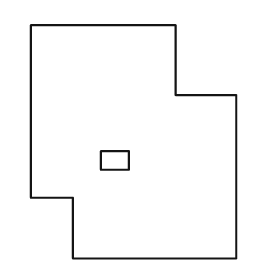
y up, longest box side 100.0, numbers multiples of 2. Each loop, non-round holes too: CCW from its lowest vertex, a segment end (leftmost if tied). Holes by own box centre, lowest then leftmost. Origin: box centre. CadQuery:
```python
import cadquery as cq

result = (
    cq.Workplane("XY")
    .moveTo(-26.0, -50.0)
    .lineTo(44.0, -50.0)
    .lineTo(44.0, 20.0)
    .lineTo(18.0, 20.0)
    .lineTo(18.0, 50.0)
    .lineTo(-44.0, 50.0)
    .lineTo(-44.0, -24.0)
    .lineTo(-26.0, -24.0)
    .close()
    .moveTo(-14.0, -12.0)
    .lineTo(-2.0, -12.0)
    .lineTo(-2.0, -4.0)
    .lineTo(-14.0, -4.0)
    .close()
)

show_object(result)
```